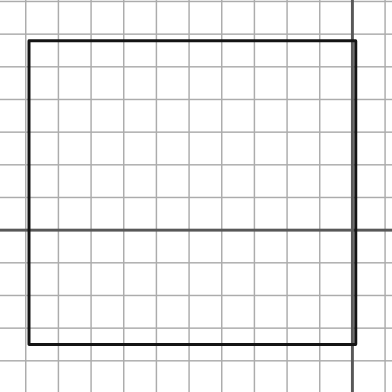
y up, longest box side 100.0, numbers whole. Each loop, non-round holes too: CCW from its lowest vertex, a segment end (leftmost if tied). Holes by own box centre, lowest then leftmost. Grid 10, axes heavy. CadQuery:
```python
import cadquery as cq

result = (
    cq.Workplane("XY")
    .moveTo(-99.0, -35.0)
    .lineTo(1.0, -35.0)
    .lineTo(1.0, 58.0)
    .lineTo(-99.0, 58.0)
    .close()
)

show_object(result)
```